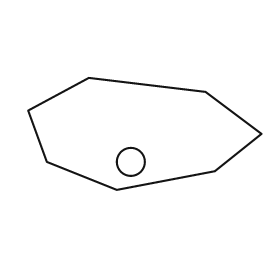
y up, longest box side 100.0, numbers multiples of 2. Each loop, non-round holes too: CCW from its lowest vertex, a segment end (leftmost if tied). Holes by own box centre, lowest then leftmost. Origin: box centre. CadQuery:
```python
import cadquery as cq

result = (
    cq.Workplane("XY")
    .moveTo(-12.0, -24.0)
    .lineTo(30.0, -16.0)
    .lineTo(50.0, 0.0)
    .lineTo(26.0, 18.0)
    .lineTo(-24.0, 24.0)
    .lineTo(-50.0, 10.0)
    .lineTo(-42.0, -12.0)
    .close()
    .moveTo(-6.0, -12.0)
    .circle(6.0)
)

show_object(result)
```